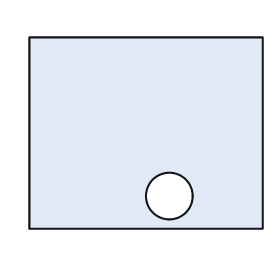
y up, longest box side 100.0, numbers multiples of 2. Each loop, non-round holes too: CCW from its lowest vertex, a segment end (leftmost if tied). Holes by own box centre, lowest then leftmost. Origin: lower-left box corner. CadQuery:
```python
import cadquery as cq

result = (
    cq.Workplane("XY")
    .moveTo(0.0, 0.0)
    .lineTo(100.0, 0.0)
    .lineTo(100.0, 82.0)
    .lineTo(0.0, 82.0)
    .close()
    .moveTo(60.0, 14.0)
    .circle(10.0)
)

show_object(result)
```